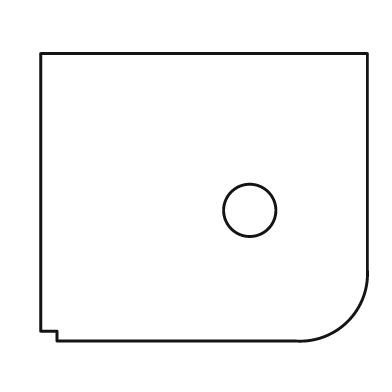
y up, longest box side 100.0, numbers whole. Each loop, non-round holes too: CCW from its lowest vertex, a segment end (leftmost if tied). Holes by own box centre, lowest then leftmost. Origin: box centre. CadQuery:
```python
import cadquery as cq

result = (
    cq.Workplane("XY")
    .moveTo(-45.0, -44.0)
    .lineTo(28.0, -44.0)
    .threePointArc((44.0, -38.0), (50.0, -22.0))
    .lineTo(50.0, 44.0)
    .lineTo(-50.0, 44.0)
    .lineTo(-50.0, -41.0)
    .lineTo(-45.0, -41.0)
    .close()
    .moveTo(14.0, -4.0)
    .circle(8.0)
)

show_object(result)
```